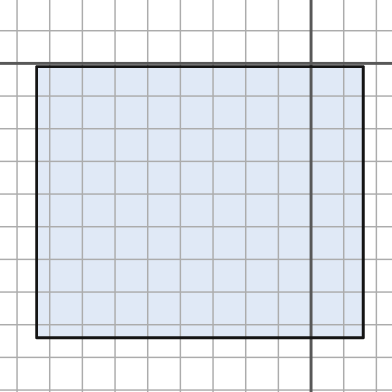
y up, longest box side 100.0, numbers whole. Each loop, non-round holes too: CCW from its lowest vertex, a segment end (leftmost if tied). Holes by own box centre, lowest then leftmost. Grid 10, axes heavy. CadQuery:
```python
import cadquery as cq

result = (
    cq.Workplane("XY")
    .moveTo(-84.0, -84.0)
    .lineTo(16.0, -84.0)
    .lineTo(16.0, -1.0)
    .lineTo(-84.0, -1.0)
    .close()
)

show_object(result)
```